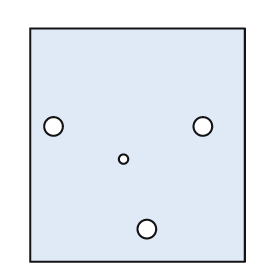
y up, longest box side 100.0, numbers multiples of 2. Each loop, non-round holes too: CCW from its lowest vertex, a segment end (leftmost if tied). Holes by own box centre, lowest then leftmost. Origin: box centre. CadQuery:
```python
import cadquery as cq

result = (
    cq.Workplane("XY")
    .moveTo(-46.0, -50.0)
    .lineTo(46.0, -50.0)
    .lineTo(46.0, 50.0)
    .lineTo(-46.0, 50.0)
    .close()
    .moveTo(4.0, -36.0)
    .circle(4.0)
    .moveTo(-6.0, -6.0)
    .circle(2.0)
    .moveTo(-36.0, 8.0)
    .circle(4.0)
    .moveTo(28.0, 8.0)
    .circle(4.0)
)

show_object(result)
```